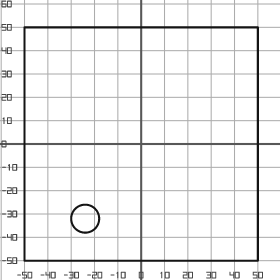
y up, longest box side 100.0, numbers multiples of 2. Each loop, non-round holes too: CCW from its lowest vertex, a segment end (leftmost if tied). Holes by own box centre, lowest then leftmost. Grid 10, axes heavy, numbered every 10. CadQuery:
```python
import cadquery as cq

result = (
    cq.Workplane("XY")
    .moveTo(-50.0, -50.0)
    .lineTo(50.0, -50.0)
    .lineTo(50.0, 50.0)
    .lineTo(-50.0, 50.0)
    .close()
    .moveTo(-24.0, -32.0)
    .circle(6.0)
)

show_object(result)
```